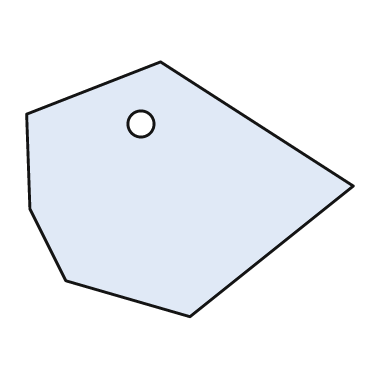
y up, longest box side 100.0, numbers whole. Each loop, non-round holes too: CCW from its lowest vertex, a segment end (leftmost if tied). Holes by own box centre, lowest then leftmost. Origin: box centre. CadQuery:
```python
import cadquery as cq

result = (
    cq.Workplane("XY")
    .moveTo(0.0, -39.0)
    .lineTo(50.0, 1.0)
    .lineTo(-9.0, 39.0)
    .lineTo(-50.0, 23.0)
    .lineTo(-49.0, -6.0)
    .lineTo(-38.0, -28.0)
    .close()
    .moveTo(-15.0, 20.0)
    .circle(4.0)
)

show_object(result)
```